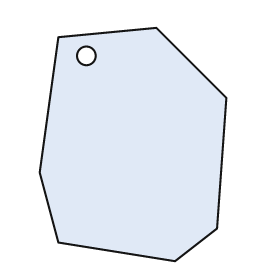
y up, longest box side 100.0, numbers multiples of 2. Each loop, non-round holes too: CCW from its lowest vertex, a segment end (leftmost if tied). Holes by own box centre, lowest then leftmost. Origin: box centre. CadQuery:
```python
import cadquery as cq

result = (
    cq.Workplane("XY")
    .moveTo(18.0, -50.0)
    .lineTo(36.0, -36.0)
    .lineTo(40.0, 20.0)
    .lineTo(10.0, 50.0)
    .lineTo(-32.0, 46.0)
    .lineTo(-40.0, -12.0)
    .lineTo(-32.0, -42.0)
    .close()
    .moveTo(-20.0, 38.0)
    .circle(4.0)
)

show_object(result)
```